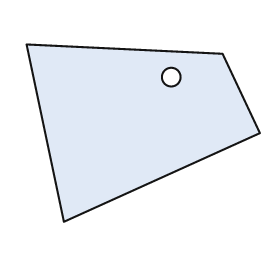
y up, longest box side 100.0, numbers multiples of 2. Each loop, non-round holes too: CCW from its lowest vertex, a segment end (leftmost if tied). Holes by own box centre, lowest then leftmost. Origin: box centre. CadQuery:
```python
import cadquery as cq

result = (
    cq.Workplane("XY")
    .moveTo(-34.0, -38.0)
    .lineTo(50.0, 0.0)
    .lineTo(34.0, 34.0)
    .lineTo(-50.0, 38.0)
    .close()
    .moveTo(12.0, 24.0)
    .circle(4.0)
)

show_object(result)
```